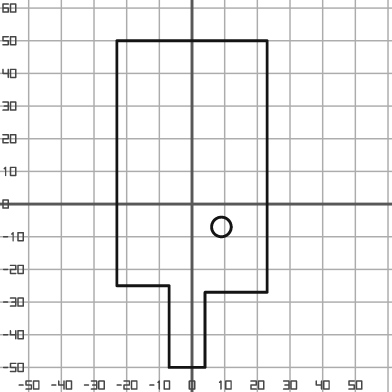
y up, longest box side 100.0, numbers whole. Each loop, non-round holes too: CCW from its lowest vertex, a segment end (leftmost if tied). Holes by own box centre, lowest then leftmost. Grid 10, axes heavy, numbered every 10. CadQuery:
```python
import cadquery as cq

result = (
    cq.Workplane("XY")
    .moveTo(-7.0, -50.0)
    .lineTo(4.0, -50.0)
    .lineTo(4.0, -27.0)
    .lineTo(23.0, -27.0)
    .lineTo(23.0, 50.0)
    .lineTo(-23.0, 50.0)
    .lineTo(-23.0, -25.0)
    .lineTo(-7.0, -25.0)
    .close()
    .moveTo(9.0, -7.0)
    .circle(3.0)
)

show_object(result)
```